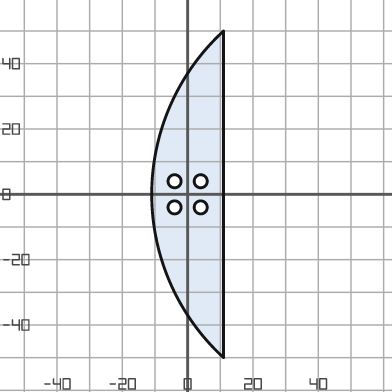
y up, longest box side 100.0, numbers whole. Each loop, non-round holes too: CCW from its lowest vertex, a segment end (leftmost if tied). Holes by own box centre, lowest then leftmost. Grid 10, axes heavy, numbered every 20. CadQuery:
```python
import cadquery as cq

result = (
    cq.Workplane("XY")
    .moveTo(11.0, -50.0)
    .lineTo(11.0, 50.0)
    .threePointArc((-11.0, 0.0), (11.0, -50.0))
    .close()
    .moveTo(-4.0, -4.0)
    .circle(2.0)
    .moveTo(4.0, -4.0)
    .circle(2.0)
    .moveTo(-4.0, 4.0)
    .circle(2.0)
    .moveTo(4.0, 4.0)
    .circle(2.0)
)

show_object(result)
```